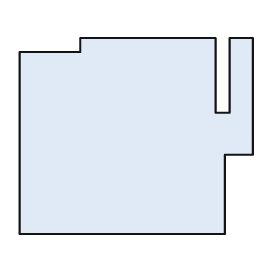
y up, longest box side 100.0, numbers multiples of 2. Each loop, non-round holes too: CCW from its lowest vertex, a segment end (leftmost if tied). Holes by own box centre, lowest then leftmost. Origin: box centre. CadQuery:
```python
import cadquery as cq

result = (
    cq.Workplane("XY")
    .moveTo(-50.0, -42.0)
    .lineTo(38.0, -42.0)
    .lineTo(38.0, -8.0)
    .lineTo(50.0, -8.0)
    .lineTo(50.0, 42.0)
    .lineTo(40.0, 42.0)
    .lineTo(40.0, 10.0)
    .lineTo(34.0, 10.0)
    .lineTo(34.0, 42.0)
    .lineTo(-24.0, 42.0)
    .lineTo(-24.0, 36.0)
    .lineTo(-50.0, 36.0)
    .close()
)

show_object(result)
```